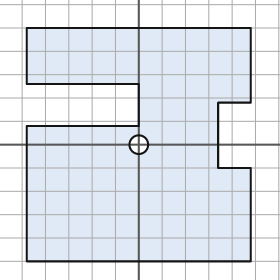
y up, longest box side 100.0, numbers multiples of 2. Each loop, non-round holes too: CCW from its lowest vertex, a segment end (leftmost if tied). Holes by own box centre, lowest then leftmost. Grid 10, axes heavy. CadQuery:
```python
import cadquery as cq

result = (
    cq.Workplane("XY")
    .moveTo(-48.0, -50.0)
    .lineTo(48.0, -50.0)
    .lineTo(48.0, -10.0)
    .lineTo(34.0, -10.0)
    .lineTo(34.0, 18.0)
    .lineTo(48.0, 18.0)
    .lineTo(48.0, 50.0)
    .lineTo(-48.0, 50.0)
    .lineTo(-48.0, 26.0)
    .lineTo(0.0, 26.0)
    .lineTo(0.0, 8.0)
    .lineTo(-48.0, 8.0)
    .close()
    .moveTo(0.0, 0.0)
    .circle(4.0)
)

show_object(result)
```